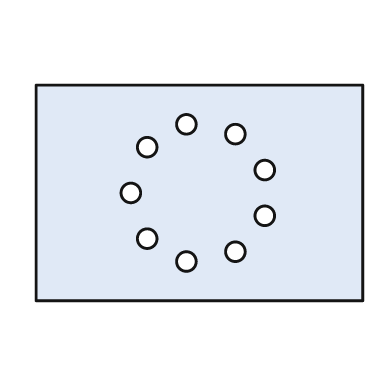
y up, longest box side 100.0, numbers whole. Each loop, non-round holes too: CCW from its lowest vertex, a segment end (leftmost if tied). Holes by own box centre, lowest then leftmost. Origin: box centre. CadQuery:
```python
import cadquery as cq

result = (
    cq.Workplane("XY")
    .moveTo(-50.0, -33.0)
    .lineTo(50.0, -33.0)
    .lineTo(50.0, 33.0)
    .lineTo(-50.0, 33.0)
    .close()
    .moveTo(-4.0, -21.0)
    .circle(3.0)
    .moveTo(11.0, -18.0)
    .circle(3.0)
    .moveTo(-16.0, -14.0)
    .circle(3.0)
    .moveTo(20.0, -7.0)
    .circle(3.0)
    .moveTo(-21.0, 0.0)
    .circle(3.0)
    .moveTo(20.0, 7.0)
    .circle(3.0)
    .moveTo(-16.0, 14.0)
    .circle(3.0)
    .moveTo(11.0, 18.0)
    .circle(3.0)
    .moveTo(-4.0, 21.0)
    .circle(3.0)
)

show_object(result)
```